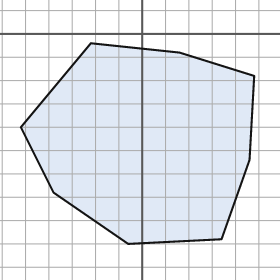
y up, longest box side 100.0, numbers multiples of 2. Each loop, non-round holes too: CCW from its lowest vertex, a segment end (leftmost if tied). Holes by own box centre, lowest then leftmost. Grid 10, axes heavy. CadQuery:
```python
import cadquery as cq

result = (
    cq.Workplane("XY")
    .moveTo(-6.0, -90.0)
    .lineTo(34.0, -88.0)
    .lineTo(46.0, -54.0)
    .lineTo(48.0, -18.0)
    .lineTo(16.0, -8.0)
    .lineTo(-22.0, -4.0)
    .lineTo(-52.0, -40.0)
    .lineTo(-38.0, -68.0)
    .close()
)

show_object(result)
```